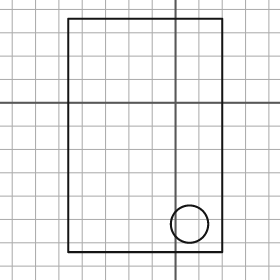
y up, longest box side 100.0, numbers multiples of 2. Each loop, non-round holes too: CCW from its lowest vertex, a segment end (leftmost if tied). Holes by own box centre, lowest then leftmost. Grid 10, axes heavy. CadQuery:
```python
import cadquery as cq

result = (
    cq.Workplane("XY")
    .moveTo(-46.0, -64.0)
    .lineTo(20.0, -64.0)
    .lineTo(20.0, 36.0)
    .lineTo(-46.0, 36.0)
    .close()
    .moveTo(6.0, -52.0)
    .circle(8.0)
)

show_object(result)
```